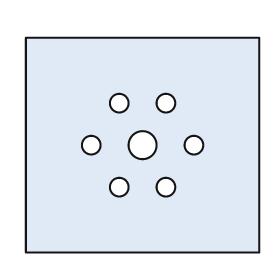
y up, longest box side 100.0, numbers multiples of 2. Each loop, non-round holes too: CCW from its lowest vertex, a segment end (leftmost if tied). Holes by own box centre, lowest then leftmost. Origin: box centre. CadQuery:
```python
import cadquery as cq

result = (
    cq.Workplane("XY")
    .moveTo(-50.0, -46.0)
    .lineTo(50.0, -46.0)
    .lineTo(50.0, 46.0)
    .lineTo(-50.0, 46.0)
    .close()
    .moveTo(-10.0, -18.0)
    .circle(4.0)
    .moveTo(10.0, -18.0)
    .circle(4.0)
    .moveTo(-22.0, 0.0)
    .circle(4.0)
    .moveTo(0.0, 0.0)
    .circle(6.0)
    .moveTo(22.0, 0.0)
    .circle(4.0)
    .moveTo(-10.0, 18.0)
    .circle(4.0)
    .moveTo(10.0, 18.0)
    .circle(4.0)
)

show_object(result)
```